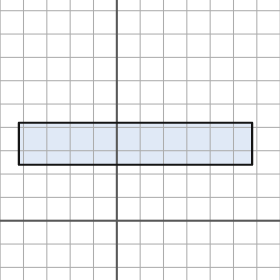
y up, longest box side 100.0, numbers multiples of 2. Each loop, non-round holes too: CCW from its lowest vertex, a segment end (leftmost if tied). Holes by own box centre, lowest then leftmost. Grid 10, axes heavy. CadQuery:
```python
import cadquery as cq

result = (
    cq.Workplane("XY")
    .moveTo(-42.0, 24.0)
    .lineTo(58.0, 24.0)
    .lineTo(58.0, 42.0)
    .lineTo(-42.0, 42.0)
    .close()
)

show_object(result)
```